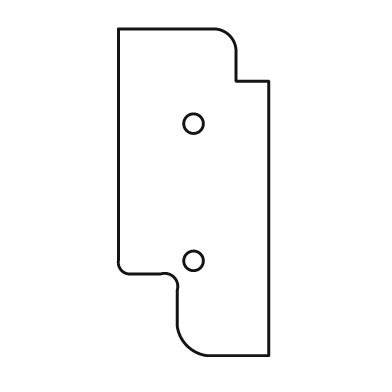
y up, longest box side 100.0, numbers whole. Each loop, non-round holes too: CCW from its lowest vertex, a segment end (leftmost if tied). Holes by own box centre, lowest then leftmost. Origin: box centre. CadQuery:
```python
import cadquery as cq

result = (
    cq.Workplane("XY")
    .moveTo(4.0, -50.0)
    .lineTo(23.0, -50.0)
    .lineTo(23.0, 34.0)
    .lineTo(13.0, 34.0)
    .lineTo(13.0, 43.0)
    .threePointArc((11.0, 48.0), (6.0, 50.0))
    .lineTo(-23.0, 50.0)
    .lineTo(-23.0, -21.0)
    .threePointArc((-22.0, -24.0), (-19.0, -25.0))
    .lineTo(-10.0, -25.0)
    .threePointArc((-6.0, -26.0), (-5.0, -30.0))
    .lineTo(-5.0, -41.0)
    .threePointArc((-2.0, -47.0), (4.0, -50.0))
    .close()
    .moveTo(0.0, -21.0)
    .circle(3.0)
    .moveTo(0.0, 21.0)
    .circle(3.0)
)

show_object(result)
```